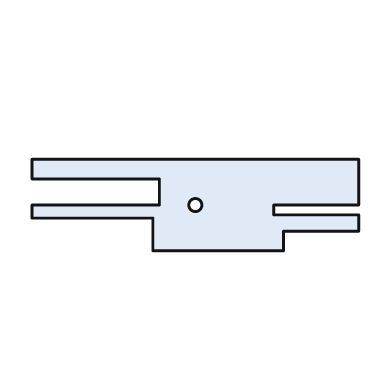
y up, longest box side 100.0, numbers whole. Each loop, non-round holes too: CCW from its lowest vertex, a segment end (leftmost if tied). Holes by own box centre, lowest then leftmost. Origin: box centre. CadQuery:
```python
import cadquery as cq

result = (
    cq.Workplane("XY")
    .moveTo(-13.0, -14.0)
    .lineTo(27.0, -14.0)
    .lineTo(27.0, -8.0)
    .lineTo(50.0, -8.0)
    .lineTo(50.0, -3.0)
    .lineTo(24.0, -3.0)
    .lineTo(24.0, 0.0)
    .lineTo(50.0, 0.0)
    .lineTo(50.0, 14.0)
    .lineTo(-50.0, 14.0)
    .lineTo(-50.0, 8.0)
    .lineTo(-11.0, 8.0)
    .lineTo(-11.0, 0.0)
    .lineTo(-50.0, 0.0)
    .lineTo(-50.0, -4.0)
    .lineTo(-13.0, -4.0)
    .close()
    .moveTo(0.0, 0.0)
    .circle(2.0)
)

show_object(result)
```